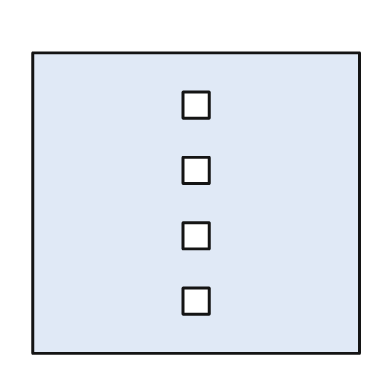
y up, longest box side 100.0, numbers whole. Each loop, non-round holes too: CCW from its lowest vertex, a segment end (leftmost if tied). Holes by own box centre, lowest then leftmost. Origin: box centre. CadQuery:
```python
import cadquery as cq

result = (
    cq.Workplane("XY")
    .moveTo(-50.0, -46.0)
    .lineTo(50.0, -46.0)
    .lineTo(50.0, 46.0)
    .lineTo(-50.0, 46.0)
    .close()
    .moveTo(-4.0, -34.0)
    .lineTo(4.0, -34.0)
    .lineTo(4.0, -26.0)
    .lineTo(-4.0, -26.0)
    .close()
    .moveTo(-4.0, -14.0)
    .lineTo(4.0, -14.0)
    .lineTo(4.0, -6.0)
    .lineTo(-4.0, -6.0)
    .close()
    .moveTo(-4.0, 6.0)
    .lineTo(4.0, 6.0)
    .lineTo(4.0, 14.0)
    .lineTo(-4.0, 14.0)
    .close()
    .moveTo(-4.0, 26.0)
    .lineTo(4.0, 26.0)
    .lineTo(4.0, 34.0)
    .lineTo(-4.0, 34.0)
    .close()
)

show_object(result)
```